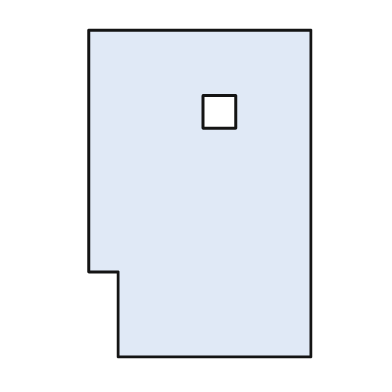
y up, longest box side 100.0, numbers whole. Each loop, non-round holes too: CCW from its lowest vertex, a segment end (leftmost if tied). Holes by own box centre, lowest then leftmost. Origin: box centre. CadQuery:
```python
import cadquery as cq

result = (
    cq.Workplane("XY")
    .moveTo(-25.0, -50.0)
    .lineTo(34.0, -50.0)
    .lineTo(34.0, 50.0)
    .lineTo(-34.0, 50.0)
    .lineTo(-34.0, -24.0)
    .lineTo(-25.0, -24.0)
    .close()
    .moveTo(1.0, 20.0)
    .lineTo(11.0, 20.0)
    .lineTo(11.0, 30.0)
    .lineTo(1.0, 30.0)
    .close()
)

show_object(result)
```